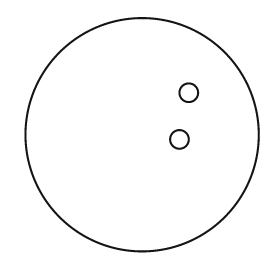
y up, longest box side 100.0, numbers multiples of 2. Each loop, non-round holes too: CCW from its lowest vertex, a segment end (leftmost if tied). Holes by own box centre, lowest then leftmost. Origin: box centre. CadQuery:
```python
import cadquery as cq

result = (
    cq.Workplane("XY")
    .moveTo(0.0, 0.0)
    .circle(50.0)
    .moveTo(16.0, -2.0)
    .circle(4.0)
    .moveTo(20.0, 18.0)
    .circle(4.0)
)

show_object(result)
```